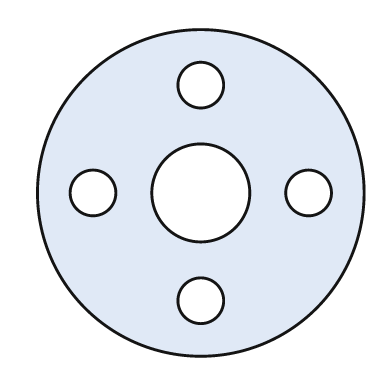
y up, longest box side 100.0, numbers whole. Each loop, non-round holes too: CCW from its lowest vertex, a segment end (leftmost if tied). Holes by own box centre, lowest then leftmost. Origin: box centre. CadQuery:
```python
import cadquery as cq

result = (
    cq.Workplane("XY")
    .moveTo(0.0, 0.0)
    .circle(50.0)
    .moveTo(0.0, -33.0)
    .circle(7.0)
    .moveTo(-33.0, 0.0)
    .circle(7.0)
    .moveTo(0.0, 0.0)
    .circle(15.0)
    .moveTo(33.0, 0.0)
    .circle(7.0)
    .moveTo(0.0, 33.0)
    .circle(7.0)
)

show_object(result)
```